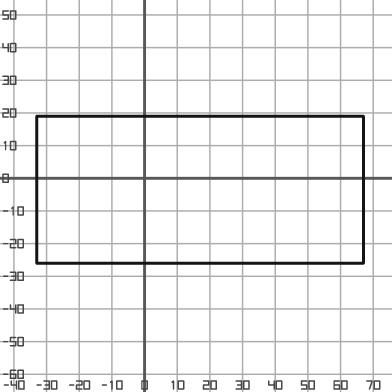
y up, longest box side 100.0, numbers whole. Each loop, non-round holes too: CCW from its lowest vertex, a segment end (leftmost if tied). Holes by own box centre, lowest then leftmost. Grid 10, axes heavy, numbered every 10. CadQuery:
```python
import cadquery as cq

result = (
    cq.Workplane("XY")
    .moveTo(-33.0, -26.0)
    .lineTo(67.0, -26.0)
    .lineTo(67.0, 19.0)
    .lineTo(-33.0, 19.0)
    .close()
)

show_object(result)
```